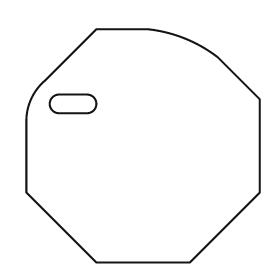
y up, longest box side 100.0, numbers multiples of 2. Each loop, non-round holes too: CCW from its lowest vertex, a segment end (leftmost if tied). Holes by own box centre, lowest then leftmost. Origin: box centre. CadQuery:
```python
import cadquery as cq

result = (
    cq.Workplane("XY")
    .moveTo(-20.0, -50.0)
    .lineTo(20.0, -50.0)
    .lineTo(50.0, -20.0)
    .lineTo(50.0, 20.0)
    .lineTo(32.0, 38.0)
    .threePointArc((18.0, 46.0), (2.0, 50.0))
    .lineTo(-20.0, 50.0)
    .lineTo(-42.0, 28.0)
    .threePointArc((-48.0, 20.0), (-50.0, 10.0))
    .lineTo(-50.0, -20.0)
    .close()
    .moveTo(-36.0, 14.0)
    .lineTo(-24.0, 14.0)
    .threePointArc((-20.0, 18.0), (-24.0, 22.0))
    .lineTo(-36.0, 22.0)
    .threePointArc((-40.0, 18.0), (-36.0, 14.0))
    .close()
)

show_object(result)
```